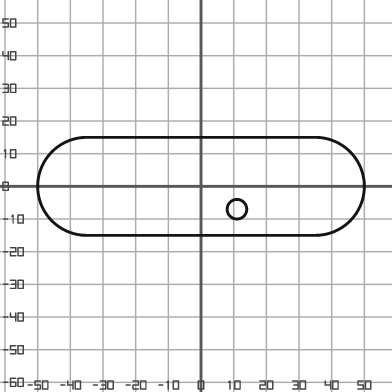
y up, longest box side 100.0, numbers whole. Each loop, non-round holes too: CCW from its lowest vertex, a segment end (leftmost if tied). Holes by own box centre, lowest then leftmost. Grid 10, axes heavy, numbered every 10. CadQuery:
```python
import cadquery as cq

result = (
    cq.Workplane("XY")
    .moveTo(-35.0, -15.0)
    .lineTo(35.0, -15.0)
    .threePointArc((50.0, 0.0), (35.0, 15.0))
    .lineTo(-35.0, 15.0)
    .threePointArc((-50.0, 0.0), (-35.0, -15.0))
    .close()
    .moveTo(11.0, -7.0)
    .circle(3.0)
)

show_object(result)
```